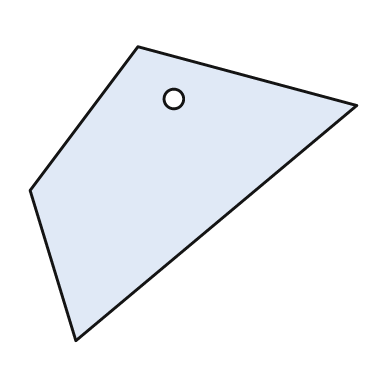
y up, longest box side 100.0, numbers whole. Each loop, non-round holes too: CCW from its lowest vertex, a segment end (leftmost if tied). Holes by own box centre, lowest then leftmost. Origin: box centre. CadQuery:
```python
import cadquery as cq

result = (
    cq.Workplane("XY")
    .moveTo(-36.0, -45.0)
    .lineTo(50.0, 27.0)
    .lineTo(-17.0, 45.0)
    .lineTo(-50.0, 1.0)
    .close()
    .moveTo(-6.0, 29.0)
    .circle(3.0)
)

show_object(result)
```